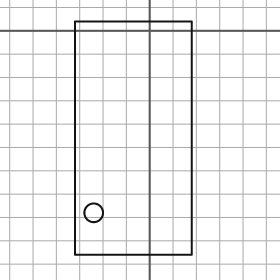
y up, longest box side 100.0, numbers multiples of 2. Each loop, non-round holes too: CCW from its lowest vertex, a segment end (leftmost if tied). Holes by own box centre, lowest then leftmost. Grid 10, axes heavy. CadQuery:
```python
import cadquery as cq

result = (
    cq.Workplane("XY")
    .moveTo(-32.0, -96.0)
    .lineTo(18.0, -96.0)
    .lineTo(18.0, 4.0)
    .lineTo(-32.0, 4.0)
    .close()
    .moveTo(-24.0, -78.0)
    .circle(4.0)
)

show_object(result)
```